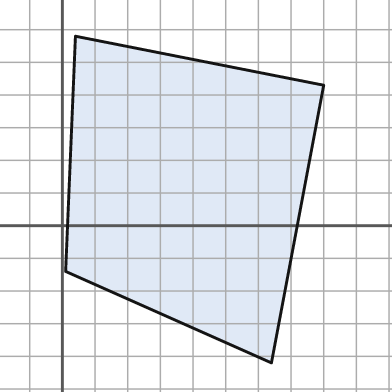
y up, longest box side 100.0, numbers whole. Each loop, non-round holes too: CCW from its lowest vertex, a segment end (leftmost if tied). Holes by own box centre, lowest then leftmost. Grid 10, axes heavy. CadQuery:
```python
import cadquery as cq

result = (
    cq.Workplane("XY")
    .moveTo(64.0, -42.0)
    .lineTo(80.0, 43.0)
    .lineTo(4.0, 58.0)
    .lineTo(1.0, -14.0)
    .close()
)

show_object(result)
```